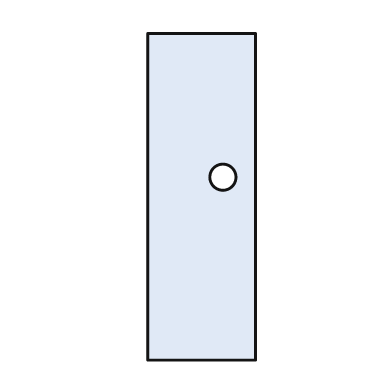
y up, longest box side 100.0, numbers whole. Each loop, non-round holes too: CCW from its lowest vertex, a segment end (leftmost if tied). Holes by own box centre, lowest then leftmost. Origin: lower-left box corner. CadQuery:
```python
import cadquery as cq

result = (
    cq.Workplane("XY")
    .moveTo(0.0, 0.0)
    .lineTo(33.0, 0.0)
    .lineTo(33.0, 100.0)
    .lineTo(0.0, 100.0)
    .close()
    .moveTo(23.0, 56.0)
    .circle(4.0)
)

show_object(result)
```